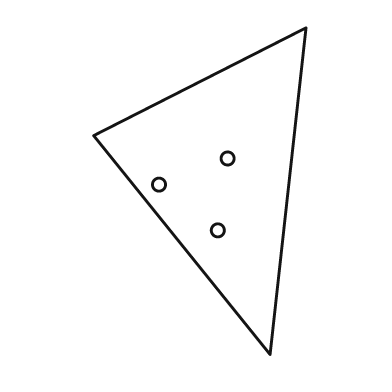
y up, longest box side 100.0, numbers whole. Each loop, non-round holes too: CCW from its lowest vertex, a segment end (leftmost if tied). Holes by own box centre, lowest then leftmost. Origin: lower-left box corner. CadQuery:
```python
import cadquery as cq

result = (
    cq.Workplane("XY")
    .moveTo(54.0, 0.0)
    .lineTo(65.0, 100.0)
    .lineTo(0.0, 67.0)
    .close()
    .moveTo(38.0, 38.0)
    .circle(2.0)
    .moveTo(20.0, 52.0)
    .circle(2.0)
    .moveTo(41.0, 60.0)
    .circle(2.0)
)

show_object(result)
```